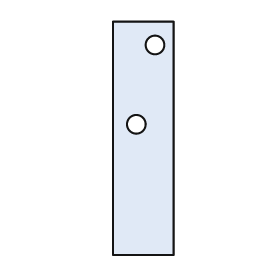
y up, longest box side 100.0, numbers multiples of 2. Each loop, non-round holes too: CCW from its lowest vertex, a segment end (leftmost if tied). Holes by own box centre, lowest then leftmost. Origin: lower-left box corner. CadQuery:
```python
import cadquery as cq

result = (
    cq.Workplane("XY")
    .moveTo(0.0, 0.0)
    .lineTo(26.0, 0.0)
    .lineTo(26.0, 100.0)
    .lineTo(0.0, 100.0)
    .close()
    .moveTo(10.0, 56.0)
    .circle(4.0)
    .moveTo(18.0, 90.0)
    .circle(4.0)
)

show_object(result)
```